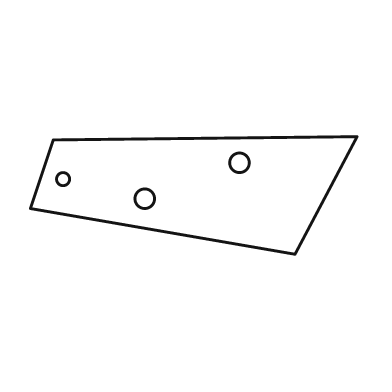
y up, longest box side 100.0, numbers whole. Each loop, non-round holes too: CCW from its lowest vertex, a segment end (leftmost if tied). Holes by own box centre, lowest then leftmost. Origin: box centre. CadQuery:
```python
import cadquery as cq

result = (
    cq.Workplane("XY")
    .moveTo(31.0, -18.0)
    .lineTo(50.0, 18.0)
    .lineTo(-43.0, 17.0)
    .lineTo(-50.0, -4.0)
    .close()
    .moveTo(-15.0, -1.0)
    .circle(3.0)
    .moveTo(-40.0, 5.0)
    .circle(2.0)
    .moveTo(14.0, 10.0)
    .circle(3.0)
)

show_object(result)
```